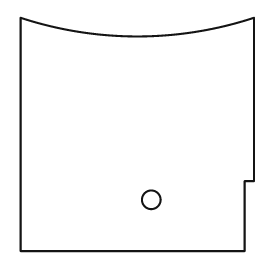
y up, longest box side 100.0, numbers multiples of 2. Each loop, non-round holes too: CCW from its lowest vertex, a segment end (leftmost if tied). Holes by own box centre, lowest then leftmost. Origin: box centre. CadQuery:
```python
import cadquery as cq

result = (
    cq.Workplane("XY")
    .moveTo(-50.0, -50.0)
    .lineTo(46.0, -50.0)
    .lineTo(46.0, -20.0)
    .lineTo(50.0, -20.0)
    .lineTo(50.0, 50.0)
    .threePointArc((0.0, 42.0), (-50.0, 50.0))
    .close()
    .moveTo(6.0, -28.0)
    .circle(4.0)
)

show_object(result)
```